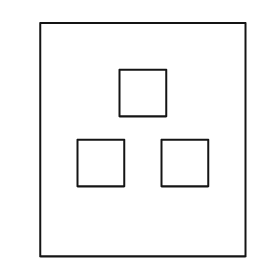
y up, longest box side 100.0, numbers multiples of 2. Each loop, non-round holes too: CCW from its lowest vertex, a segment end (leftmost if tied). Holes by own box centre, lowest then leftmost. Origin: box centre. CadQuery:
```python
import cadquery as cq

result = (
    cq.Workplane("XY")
    .moveTo(-44.0, -50.0)
    .lineTo(44.0, -50.0)
    .lineTo(44.0, 50.0)
    .lineTo(-44.0, 50.0)
    .close()
    .moveTo(-28.0, -20.0)
    .lineTo(-8.0, -20.0)
    .lineTo(-8.0, 0.0)
    .lineTo(-28.0, 0.0)
    .close()
    .moveTo(8.0, -20.0)
    .lineTo(28.0, -20.0)
    .lineTo(28.0, 0.0)
    .lineTo(8.0, 0.0)
    .close()
    .moveTo(-10.0, 10.0)
    .lineTo(10.0, 10.0)
    .lineTo(10.0, 30.0)
    .lineTo(-10.0, 30.0)
    .close()
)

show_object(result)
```